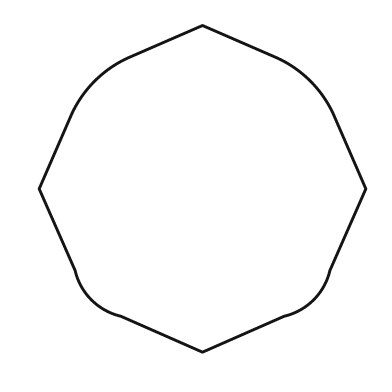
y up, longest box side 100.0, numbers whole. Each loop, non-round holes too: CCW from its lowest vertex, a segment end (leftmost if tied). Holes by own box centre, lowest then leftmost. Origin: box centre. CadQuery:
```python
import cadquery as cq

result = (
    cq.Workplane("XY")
    .moveTo(0.0, -50.0)
    .lineTo(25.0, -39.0)
    .threePointArc((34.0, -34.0), (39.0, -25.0))
    .lineTo(50.0, 0.0)
    .lineTo(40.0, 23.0)
    .threePointArc((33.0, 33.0), (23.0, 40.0))
    .lineTo(0.0, 50.0)
    .lineTo(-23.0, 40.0)
    .threePointArc((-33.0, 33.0), (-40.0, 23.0))
    .lineTo(-50.0, 0.0)
    .lineTo(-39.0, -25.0)
    .threePointArc((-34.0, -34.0), (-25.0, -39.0))
    .close()
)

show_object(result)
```